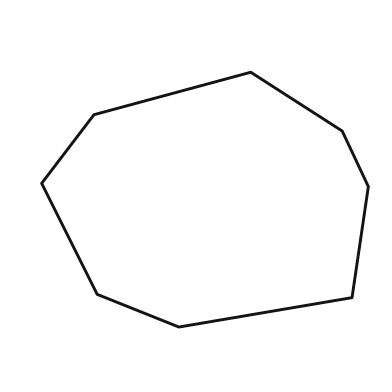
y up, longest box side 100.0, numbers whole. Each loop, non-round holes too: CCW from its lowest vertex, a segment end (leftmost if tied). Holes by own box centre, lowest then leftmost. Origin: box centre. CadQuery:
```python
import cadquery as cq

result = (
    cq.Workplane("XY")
    .moveTo(-8.0, -39.0)
    .lineTo(45.0, -30.0)
    .lineTo(50.0, 4.0)
    .lineTo(42.0, 21.0)
    .lineTo(14.0, 39.0)
    .lineTo(-34.0, 26.0)
    .lineTo(-50.0, 5.0)
    .lineTo(-33.0, -29.0)
    .close()
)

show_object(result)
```